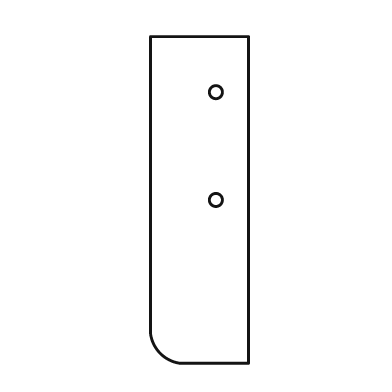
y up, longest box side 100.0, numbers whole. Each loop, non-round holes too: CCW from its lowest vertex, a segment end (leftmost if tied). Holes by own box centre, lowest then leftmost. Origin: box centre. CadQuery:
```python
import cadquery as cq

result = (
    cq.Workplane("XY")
    .moveTo(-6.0, -50.0)
    .lineTo(15.0, -50.0)
    .lineTo(15.0, 50.0)
    .lineTo(-15.0, 50.0)
    .lineTo(-15.0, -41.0)
    .threePointArc((-12.0, -47.0), (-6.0, -50.0))
    .close()
    .moveTo(5.0, 0.0)
    .circle(2.0)
    .moveTo(5.0, 33.0)
    .circle(2.0)
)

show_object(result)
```